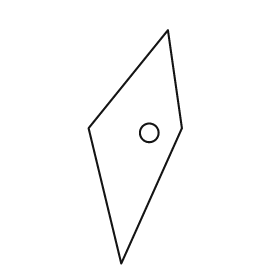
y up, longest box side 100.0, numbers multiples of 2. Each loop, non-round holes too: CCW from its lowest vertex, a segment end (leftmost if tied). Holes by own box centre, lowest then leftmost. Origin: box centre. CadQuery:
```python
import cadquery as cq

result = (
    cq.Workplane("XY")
    .moveTo(-6.0, -50.0)
    .lineTo(20.0, 8.0)
    .lineTo(14.0, 50.0)
    .lineTo(-20.0, 8.0)
    .close()
    .moveTo(6.0, 6.0)
    .circle(4.0)
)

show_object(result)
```